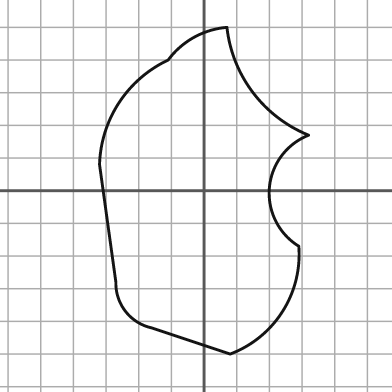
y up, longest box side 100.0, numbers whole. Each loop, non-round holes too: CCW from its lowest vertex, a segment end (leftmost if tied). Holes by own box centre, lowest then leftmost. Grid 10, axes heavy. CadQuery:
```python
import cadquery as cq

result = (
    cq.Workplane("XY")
    .moveTo(8.0, -50.0)
    .threePointArc((24.0, -37.0), (29.0, -17.0))
    .threePointArc((20.0, 1.0), (32.0, 17.0))
    .threePointArc((15.0, 30.0), (7.0, 50.0))
    .threePointArc((-3.0, 47.0), (-11.0, 40.0))
    .threePointArc((-26.0, 27.0), (-32.0, 8.0))
    .lineTo(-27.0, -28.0)
    .threePointArc((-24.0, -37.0), (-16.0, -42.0))
    .close()
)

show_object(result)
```